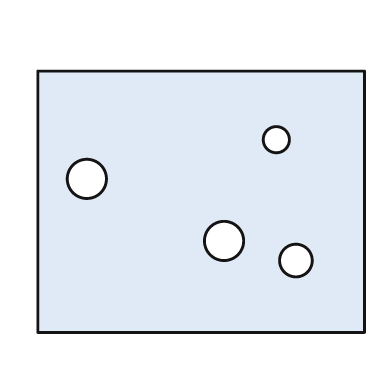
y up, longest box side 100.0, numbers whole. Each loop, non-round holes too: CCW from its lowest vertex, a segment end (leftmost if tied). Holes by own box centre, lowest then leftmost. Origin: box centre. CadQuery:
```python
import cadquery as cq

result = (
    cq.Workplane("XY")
    .moveTo(-50.0, -40.0)
    .lineTo(50.0, -40.0)
    .lineTo(50.0, 40.0)
    .lineTo(-50.0, 40.0)
    .close()
    .moveTo(29.0, -18.0)
    .circle(5.0)
    .moveTo(7.0, -12.0)
    .circle(6.0)
    .moveTo(-35.0, 7.0)
    .circle(6.0)
    .moveTo(23.0, 19.0)
    .circle(4.0)
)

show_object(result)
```